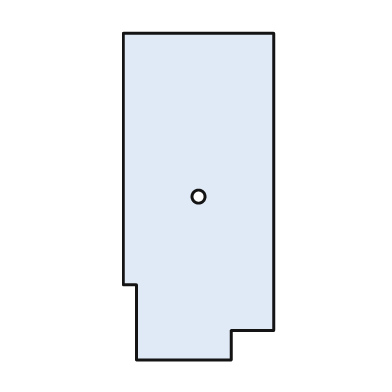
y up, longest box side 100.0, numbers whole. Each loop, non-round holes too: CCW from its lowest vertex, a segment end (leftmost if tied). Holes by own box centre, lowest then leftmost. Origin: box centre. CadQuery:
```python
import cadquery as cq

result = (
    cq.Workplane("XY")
    .moveTo(-19.0, -50.0)
    .lineTo(10.0, -50.0)
    .lineTo(10.0, -41.0)
    .lineTo(23.0, -41.0)
    .lineTo(23.0, 50.0)
    .lineTo(-23.0, 50.0)
    .lineTo(-23.0, -27.0)
    .lineTo(-19.0, -27.0)
    .close()
    .moveTo(0.0, 0.0)
    .circle(2.0)
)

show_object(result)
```